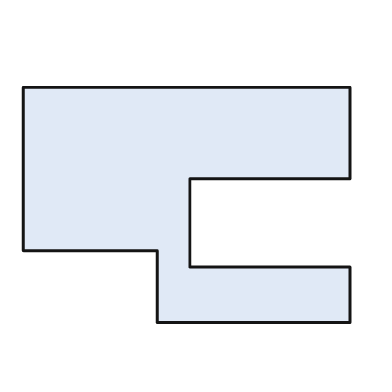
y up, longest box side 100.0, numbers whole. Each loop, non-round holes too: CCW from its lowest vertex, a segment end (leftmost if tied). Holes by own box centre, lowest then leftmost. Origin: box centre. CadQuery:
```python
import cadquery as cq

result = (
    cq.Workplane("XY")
    .moveTo(-9.0, -36.0)
    .lineTo(50.0, -36.0)
    .lineTo(50.0, -19.0)
    .lineTo(1.0, -19.0)
    .lineTo(1.0, 8.0)
    .lineTo(50.0, 8.0)
    .lineTo(50.0, 36.0)
    .lineTo(-50.0, 36.0)
    .lineTo(-50.0, -14.0)
    .lineTo(-9.0, -14.0)
    .close()
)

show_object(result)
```